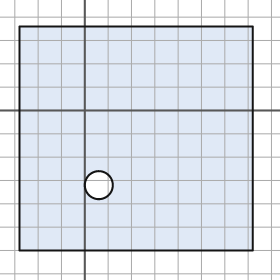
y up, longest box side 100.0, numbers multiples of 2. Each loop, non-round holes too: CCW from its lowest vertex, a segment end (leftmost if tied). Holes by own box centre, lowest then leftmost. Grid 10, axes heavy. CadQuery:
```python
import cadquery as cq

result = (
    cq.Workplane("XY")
    .moveTo(-28.0, -60.0)
    .lineTo(72.0, -60.0)
    .lineTo(72.0, 36.0)
    .lineTo(-28.0, 36.0)
    .close()
    .moveTo(6.0, -32.0)
    .circle(6.0)
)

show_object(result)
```